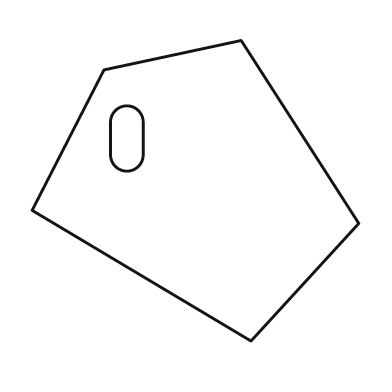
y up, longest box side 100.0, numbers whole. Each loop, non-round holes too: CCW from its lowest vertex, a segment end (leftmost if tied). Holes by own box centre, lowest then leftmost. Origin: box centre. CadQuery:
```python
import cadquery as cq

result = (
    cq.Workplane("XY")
    .moveTo(17.0, -46.0)
    .lineTo(50.0, -10.0)
    .lineTo(14.0, 46.0)
    .lineTo(-28.0, 37.0)
    .lineTo(-50.0, -6.0)
    .close()
    .moveTo(-26.0, 11.0)
    .threePointArc((-21.0, 6.0), (-16.0, 11.0))
    .lineTo(-16.0, 21.0)
    .threePointArc((-21.0, 26.0), (-26.0, 21.0))
    .close()
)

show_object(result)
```